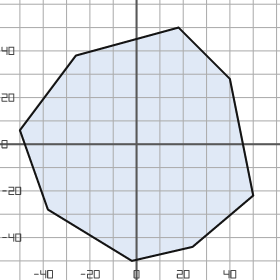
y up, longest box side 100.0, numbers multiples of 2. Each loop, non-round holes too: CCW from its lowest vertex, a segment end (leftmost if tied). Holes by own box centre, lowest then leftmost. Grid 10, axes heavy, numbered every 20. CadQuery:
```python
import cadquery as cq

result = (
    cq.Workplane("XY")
    .moveTo(-2.0, -50.0)
    .lineTo(24.0, -44.0)
    .lineTo(50.0, -22.0)
    .lineTo(40.0, 28.0)
    .lineTo(18.0, 50.0)
    .lineTo(-26.0, 38.0)
    .lineTo(-50.0, 6.0)
    .lineTo(-38.0, -28.0)
    .close()
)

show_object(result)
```